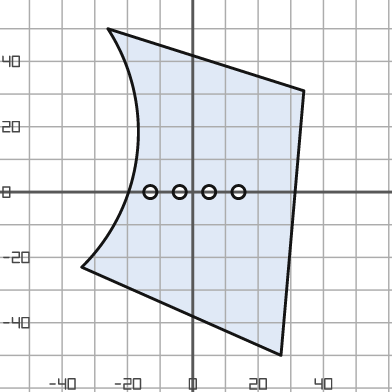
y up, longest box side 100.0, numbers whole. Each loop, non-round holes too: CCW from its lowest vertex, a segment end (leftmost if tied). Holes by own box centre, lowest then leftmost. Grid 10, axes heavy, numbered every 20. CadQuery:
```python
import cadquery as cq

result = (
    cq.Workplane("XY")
    .moveTo(27.0, -50.0)
    .lineTo(34.0, 31.0)
    .lineTo(-26.0, 50.0)
    .threePointArc((-17.0, 12.0), (-34.0, -23.0))
    .close()
    .moveTo(-13.0, 0.0)
    .circle(2.0)
    .moveTo(-4.0, 0.0)
    .circle(2.0)
    .moveTo(5.0, 0.0)
    .circle(2.0)
    .moveTo(14.0, 0.0)
    .circle(2.0)
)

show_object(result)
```